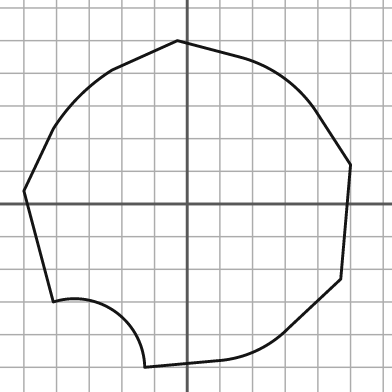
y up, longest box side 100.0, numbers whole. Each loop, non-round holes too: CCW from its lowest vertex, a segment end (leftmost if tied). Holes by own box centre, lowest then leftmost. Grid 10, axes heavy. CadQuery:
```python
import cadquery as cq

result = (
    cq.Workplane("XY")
    .moveTo(-13.0, -50.0)
    .lineTo(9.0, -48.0)
    .threePointArc((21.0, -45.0), (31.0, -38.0))
    .lineTo(47.0, -23.0)
    .lineTo(50.0, 12.0)
    .lineTo(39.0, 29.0)
    .threePointArc((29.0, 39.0), (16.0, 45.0))
    .lineTo(-3.0, 50.0)
    .lineTo(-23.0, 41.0)
    .threePointArc((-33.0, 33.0), (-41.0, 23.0))
    .lineTo(-50.0, 4.0)
    .lineTo(-41.0, -30.0)
    .threePointArc((-22.0, -33.0), (-13.0, -50.0))
    .close()
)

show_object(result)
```